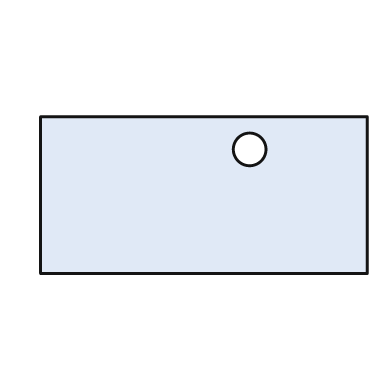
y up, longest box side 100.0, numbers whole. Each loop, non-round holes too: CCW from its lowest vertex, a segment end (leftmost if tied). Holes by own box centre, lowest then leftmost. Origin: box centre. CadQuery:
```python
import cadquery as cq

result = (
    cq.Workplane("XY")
    .moveTo(-50.0, -24.0)
    .lineTo(50.0, -24.0)
    .lineTo(50.0, 24.0)
    .lineTo(-50.0, 24.0)
    .close()
    .moveTo(14.0, 14.0)
    .circle(5.0)
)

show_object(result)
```